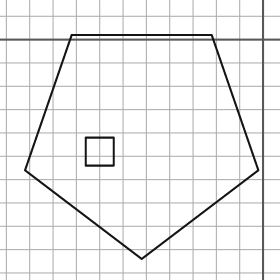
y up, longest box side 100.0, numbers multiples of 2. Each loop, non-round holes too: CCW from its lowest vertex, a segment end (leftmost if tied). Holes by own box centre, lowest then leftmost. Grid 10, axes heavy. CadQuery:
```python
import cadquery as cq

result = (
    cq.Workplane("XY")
    .moveTo(-52.0, -94.0)
    .lineTo(-2.0, -56.0)
    .lineTo(-22.0, 2.0)
    .lineTo(-82.0, 2.0)
    .lineTo(-102.0, -56.0)
    .close()
    .moveTo(-76.0, -54.0)
    .lineTo(-64.0, -54.0)
    .lineTo(-64.0, -42.0)
    .lineTo(-76.0, -42.0)
    .close()
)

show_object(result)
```